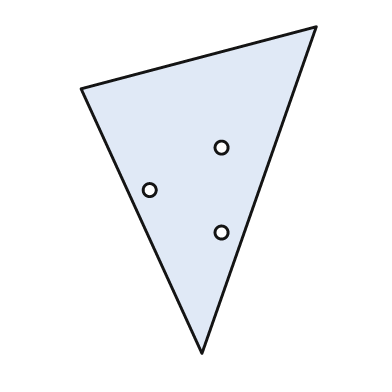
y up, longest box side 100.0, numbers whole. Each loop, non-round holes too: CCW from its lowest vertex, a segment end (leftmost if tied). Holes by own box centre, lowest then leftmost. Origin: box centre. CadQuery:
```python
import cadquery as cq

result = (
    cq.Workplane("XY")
    .moveTo(1.0, -50.0)
    .lineTo(36.0, 50.0)
    .lineTo(-36.0, 31.0)
    .close()
    .moveTo(7.0, -13.0)
    .circle(2.0)
    .moveTo(-15.0, 0.0)
    .circle(2.0)
    .moveTo(7.0, 13.0)
    .circle(2.0)
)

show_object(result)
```